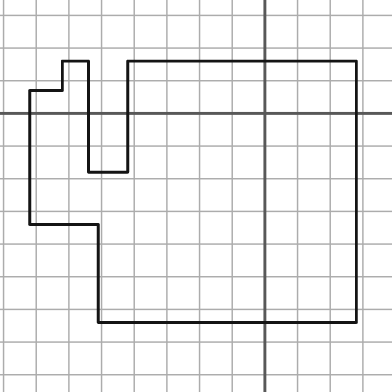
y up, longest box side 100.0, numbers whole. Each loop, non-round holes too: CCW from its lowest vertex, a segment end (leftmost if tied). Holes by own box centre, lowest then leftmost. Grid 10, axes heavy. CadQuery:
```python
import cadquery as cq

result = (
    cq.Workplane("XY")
    .moveTo(-51.0, -64.0)
    .lineTo(28.0, -64.0)
    .lineTo(28.0, 16.0)
    .lineTo(-42.0, 16.0)
    .lineTo(-42.0, -18.0)
    .lineTo(-54.0, -18.0)
    .lineTo(-54.0, 16.0)
    .lineTo(-62.0, 16.0)
    .lineTo(-62.0, 7.0)
    .lineTo(-72.0, 7.0)
    .lineTo(-72.0, -34.0)
    .lineTo(-51.0, -34.0)
    .close()
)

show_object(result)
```